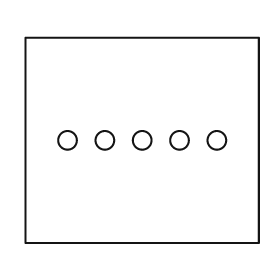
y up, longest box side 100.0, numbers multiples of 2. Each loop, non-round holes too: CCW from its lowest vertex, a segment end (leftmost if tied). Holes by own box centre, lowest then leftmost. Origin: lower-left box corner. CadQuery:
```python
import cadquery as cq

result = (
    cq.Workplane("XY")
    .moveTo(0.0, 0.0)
    .lineTo(100.0, 0.0)
    .lineTo(100.0, 88.0)
    .lineTo(0.0, 88.0)
    .close()
    .moveTo(18.0, 44.0)
    .circle(4.0)
    .moveTo(34.0, 44.0)
    .circle(4.0)
    .moveTo(50.0, 44.0)
    .circle(4.0)
    .moveTo(66.0, 44.0)
    .circle(4.0)
    .moveTo(82.0, 44.0)
    .circle(4.0)
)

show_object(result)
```